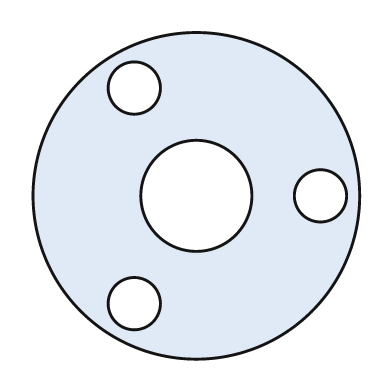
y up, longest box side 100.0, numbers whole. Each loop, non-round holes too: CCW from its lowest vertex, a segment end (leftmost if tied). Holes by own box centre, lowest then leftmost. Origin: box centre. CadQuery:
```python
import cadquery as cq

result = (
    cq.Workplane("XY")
    .moveTo(0.0, 0.0)
    .circle(50.0)
    .moveTo(-19.0, -33.0)
    .circle(8.0)
    .moveTo(0.0, 0.0)
    .circle(17.0)
    .moveTo(38.0, 0.0)
    .circle(8.0)
    .moveTo(-19.0, 33.0)
    .circle(8.0)
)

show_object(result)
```